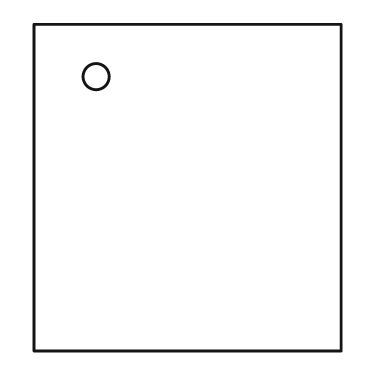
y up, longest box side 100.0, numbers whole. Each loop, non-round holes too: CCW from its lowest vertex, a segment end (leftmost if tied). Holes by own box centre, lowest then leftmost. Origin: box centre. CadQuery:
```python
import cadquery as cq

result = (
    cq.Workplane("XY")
    .moveTo(-47.0, -50.0)
    .lineTo(47.0, -50.0)
    .lineTo(47.0, 50.0)
    .lineTo(-47.0, 50.0)
    .close()
    .moveTo(-28.0, 34.0)
    .circle(4.0)
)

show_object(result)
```